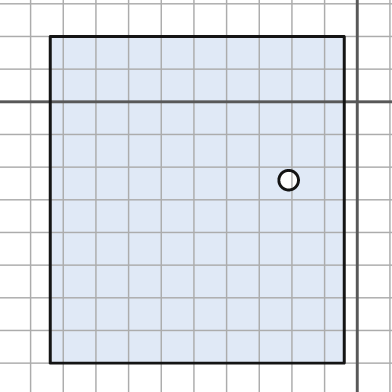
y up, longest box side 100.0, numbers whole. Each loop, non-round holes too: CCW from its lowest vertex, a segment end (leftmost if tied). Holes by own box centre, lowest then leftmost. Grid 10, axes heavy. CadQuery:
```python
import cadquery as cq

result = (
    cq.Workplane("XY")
    .moveTo(-94.0, -80.0)
    .lineTo(-4.0, -80.0)
    .lineTo(-4.0, 20.0)
    .lineTo(-94.0, 20.0)
    .close()
    .moveTo(-21.0, -24.0)
    .circle(3.0)
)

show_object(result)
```